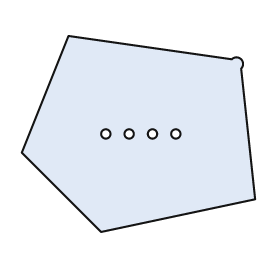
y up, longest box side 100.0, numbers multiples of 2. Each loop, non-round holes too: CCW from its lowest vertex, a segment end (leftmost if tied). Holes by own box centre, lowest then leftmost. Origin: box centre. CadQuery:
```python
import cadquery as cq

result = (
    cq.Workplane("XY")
    .moveTo(-16.0, -42.0)
    .lineTo(50.0, -28.0)
    .lineTo(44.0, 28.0)
    .threePointArc((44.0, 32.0), (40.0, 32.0))
    .lineTo(-30.0, 42.0)
    .lineTo(-50.0, -8.0)
    .close()
    .moveTo(-14.0, 0.0)
    .circle(2.0)
    .moveTo(-4.0, 0.0)
    .circle(2.0)
    .moveTo(6.0, 0.0)
    .circle(2.0)
    .moveTo(16.0, 0.0)
    .circle(2.0)
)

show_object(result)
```